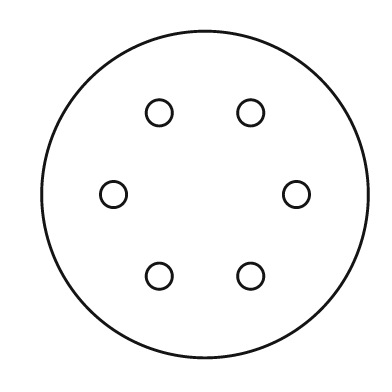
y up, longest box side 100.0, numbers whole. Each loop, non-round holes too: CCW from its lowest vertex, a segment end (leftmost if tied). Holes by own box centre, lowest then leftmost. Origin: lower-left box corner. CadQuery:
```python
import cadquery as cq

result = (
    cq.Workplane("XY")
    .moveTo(50.0, 50.0)
    .circle(50.0)
    .moveTo(36.0, 25.0)
    .circle(4.0)
    .moveTo(64.0, 25.0)
    .circle(4.0)
    .moveTo(22.0, 50.0)
    .circle(4.0)
    .moveTo(78.0, 50.0)
    .circle(4.0)
    .moveTo(36.0, 75.0)
    .circle(4.0)
    .moveTo(64.0, 75.0)
    .circle(4.0)
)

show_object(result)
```